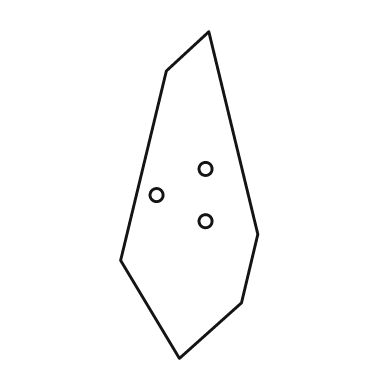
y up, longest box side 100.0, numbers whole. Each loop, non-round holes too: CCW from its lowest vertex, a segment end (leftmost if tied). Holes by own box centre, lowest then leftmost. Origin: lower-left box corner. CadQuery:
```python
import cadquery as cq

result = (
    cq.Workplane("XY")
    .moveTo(18.0, 0.0)
    .lineTo(37.0, 17.0)
    .lineTo(42.0, 38.0)
    .lineTo(27.0, 100.0)
    .lineTo(14.0, 88.0)
    .lineTo(0.0, 30.0)
    .close()
    .moveTo(26.0, 42.0)
    .circle(2.0)
    .moveTo(11.0, 50.0)
    .circle(2.0)
    .moveTo(26.0, 58.0)
    .circle(2.0)
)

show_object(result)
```